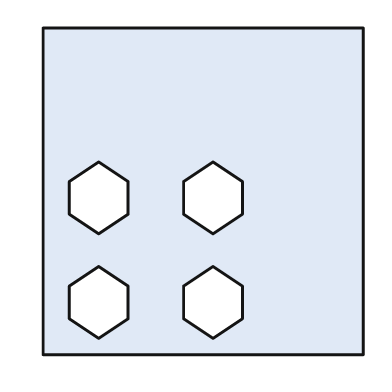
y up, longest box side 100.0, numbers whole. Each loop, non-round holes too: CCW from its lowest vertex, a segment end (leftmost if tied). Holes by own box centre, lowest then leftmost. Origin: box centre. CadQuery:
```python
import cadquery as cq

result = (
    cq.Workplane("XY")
    .moveTo(-49.0, -50.0)
    .lineTo(49.0, -50.0)
    .lineTo(49.0, 50.0)
    .lineTo(-49.0, 50.0)
    .close()
    .moveTo(-32.0, -45.0)
    .lineTo(-23.0, -39.0)
    .lineTo(-23.0, -29.0)
    .lineTo(-32.0, -23.0)
    .lineTo(-41.0, -29.0)
    .lineTo(-41.0, -39.0)
    .close()
    .moveTo(3.0, -45.0)
    .lineTo(12.0, -39.0)
    .lineTo(12.0, -29.0)
    .lineTo(3.0, -23.0)
    .lineTo(-6.0, -29.0)
    .lineTo(-6.0, -39.0)
    .close()
    .moveTo(-32.0, -13.0)
    .lineTo(-23.0, -7.0)
    .lineTo(-23.0, 3.0)
    .lineTo(-32.0, 9.0)
    .lineTo(-41.0, 3.0)
    .lineTo(-41.0, -7.0)
    .close()
    .moveTo(3.0, -13.0)
    .lineTo(12.0, -7.0)
    .lineTo(12.0, 3.0)
    .lineTo(3.0, 9.0)
    .lineTo(-6.0, 3.0)
    .lineTo(-6.0, -7.0)
    .close()
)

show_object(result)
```